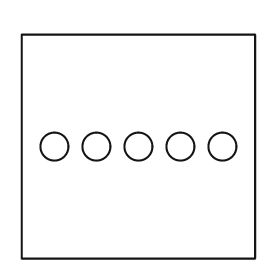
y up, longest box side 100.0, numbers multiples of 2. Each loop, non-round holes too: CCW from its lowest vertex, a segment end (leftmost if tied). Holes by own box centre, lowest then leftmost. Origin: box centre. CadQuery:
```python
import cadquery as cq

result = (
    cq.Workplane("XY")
    .moveTo(-50.0, -48.0)
    .lineTo(50.0, -48.0)
    .lineTo(50.0, 48.0)
    .lineTo(-50.0, 48.0)
    .close()
    .moveTo(-36.0, 0.0)
    .circle(6.0)
    .moveTo(-18.0, 0.0)
    .circle(6.0)
    .moveTo(0.0, 0.0)
    .circle(6.0)
    .moveTo(18.0, 0.0)
    .circle(6.0)
    .moveTo(36.0, 0.0)
    .circle(6.0)
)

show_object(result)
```